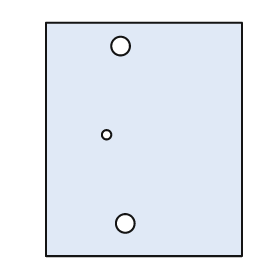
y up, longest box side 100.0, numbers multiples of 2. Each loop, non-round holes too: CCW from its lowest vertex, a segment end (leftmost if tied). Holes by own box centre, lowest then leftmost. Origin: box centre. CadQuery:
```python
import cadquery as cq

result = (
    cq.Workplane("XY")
    .moveTo(-42.0, -50.0)
    .lineTo(42.0, -50.0)
    .lineTo(42.0, 50.0)
    .lineTo(-42.0, 50.0)
    .close()
    .moveTo(-8.0, -36.0)
    .circle(4.0)
    .moveTo(-16.0, 2.0)
    .circle(2.0)
    .moveTo(-10.0, 40.0)
    .circle(4.0)
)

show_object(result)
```